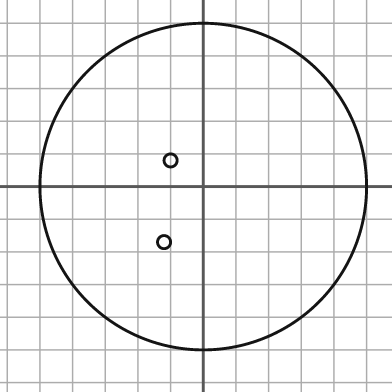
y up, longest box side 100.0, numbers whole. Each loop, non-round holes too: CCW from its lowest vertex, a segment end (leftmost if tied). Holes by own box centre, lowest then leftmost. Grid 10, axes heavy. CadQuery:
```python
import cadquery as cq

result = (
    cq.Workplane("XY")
    .moveTo(0.0, 0.0)
    .circle(50.0)
    .moveTo(-12.0, -17.0)
    .circle(2.0)
    .moveTo(-10.0, 8.0)
    .circle(2.0)
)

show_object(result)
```